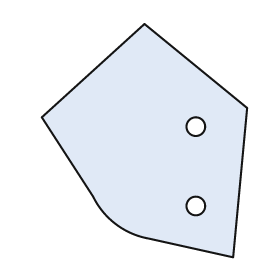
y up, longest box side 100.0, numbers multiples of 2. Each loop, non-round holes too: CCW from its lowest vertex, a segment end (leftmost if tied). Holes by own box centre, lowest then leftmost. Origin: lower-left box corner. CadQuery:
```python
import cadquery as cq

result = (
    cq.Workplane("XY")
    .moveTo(82.0, 0.0)
    .lineTo(88.0, 64.0)
    .lineTo(44.0, 100.0)
    .lineTo(0.0, 60.0)
    .lineTo(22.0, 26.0)
    .threePointArc((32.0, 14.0), (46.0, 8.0))
    .close()
    .moveTo(66.0, 22.0)
    .circle(4.0)
    .moveTo(66.0, 56.0)
    .circle(4.0)
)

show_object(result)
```